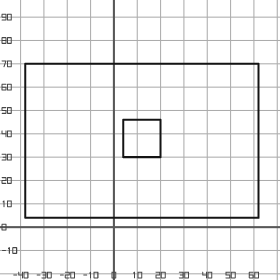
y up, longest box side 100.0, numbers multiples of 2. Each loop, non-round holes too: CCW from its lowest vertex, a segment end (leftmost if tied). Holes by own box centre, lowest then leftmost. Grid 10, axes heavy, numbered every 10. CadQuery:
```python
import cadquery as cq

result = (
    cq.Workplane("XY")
    .moveTo(-38.0, 4.0)
    .lineTo(62.0, 4.0)
    .lineTo(62.0, 70.0)
    .lineTo(-38.0, 70.0)
    .close()
    .moveTo(4.0, 30.0)
    .lineTo(20.0, 30.0)
    .lineTo(20.0, 46.0)
    .lineTo(4.0, 46.0)
    .close()
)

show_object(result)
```